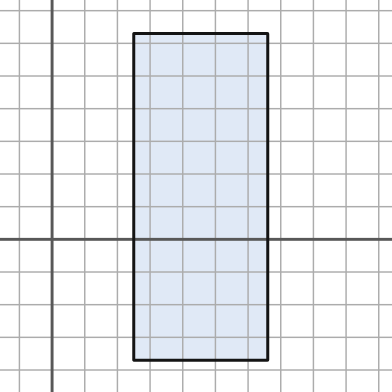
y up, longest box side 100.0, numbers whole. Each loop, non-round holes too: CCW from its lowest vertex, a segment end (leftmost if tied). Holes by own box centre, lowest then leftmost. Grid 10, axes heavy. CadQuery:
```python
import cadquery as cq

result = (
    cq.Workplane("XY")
    .moveTo(25.0, -37.0)
    .lineTo(66.0, -37.0)
    .lineTo(66.0, 63.0)
    .lineTo(25.0, 63.0)
    .close()
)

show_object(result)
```